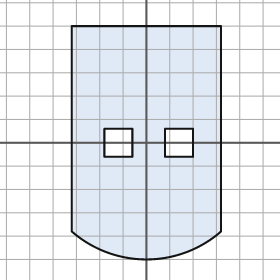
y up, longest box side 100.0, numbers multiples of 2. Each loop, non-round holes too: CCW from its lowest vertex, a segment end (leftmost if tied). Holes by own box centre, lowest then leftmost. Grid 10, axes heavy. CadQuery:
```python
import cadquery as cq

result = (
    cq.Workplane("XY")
    .moveTo(-32.0, -38.0)
    .threePointArc((0.0, -50.0), (32.0, -38.0))
    .lineTo(32.0, 50.0)
    .lineTo(-32.0, 50.0)
    .close()
    .moveTo(-18.0, -6.0)
    .lineTo(-6.0, -6.0)
    .lineTo(-6.0, 6.0)
    .lineTo(-18.0, 6.0)
    .close()
    .moveTo(8.0, -6.0)
    .lineTo(20.0, -6.0)
    .lineTo(20.0, 6.0)
    .lineTo(8.0, 6.0)
    .close()
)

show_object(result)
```